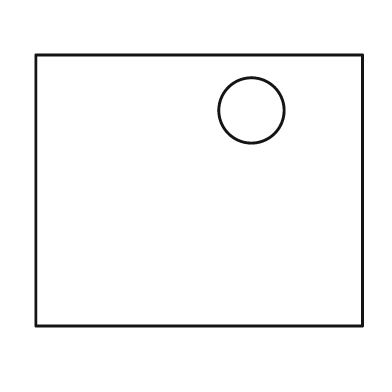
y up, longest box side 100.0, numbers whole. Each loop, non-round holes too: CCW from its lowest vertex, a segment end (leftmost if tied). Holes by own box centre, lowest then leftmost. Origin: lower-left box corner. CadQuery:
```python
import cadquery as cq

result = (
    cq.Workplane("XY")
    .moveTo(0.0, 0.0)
    .lineTo(100.0, 0.0)
    .lineTo(100.0, 83.0)
    .lineTo(0.0, 83.0)
    .close()
    .moveTo(66.0, 66.0)
    .circle(10.0)
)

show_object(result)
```